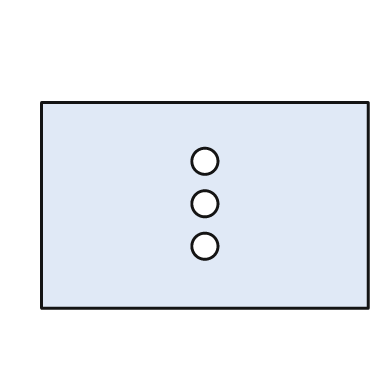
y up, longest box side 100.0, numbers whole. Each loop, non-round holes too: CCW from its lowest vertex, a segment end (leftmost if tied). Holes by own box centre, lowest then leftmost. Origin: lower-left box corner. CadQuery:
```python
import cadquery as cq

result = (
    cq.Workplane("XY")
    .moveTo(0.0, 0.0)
    .lineTo(100.0, 0.0)
    .lineTo(100.0, 63.0)
    .lineTo(0.0, 63.0)
    .close()
    .moveTo(50.0, 19.0)
    .circle(4.0)
    .moveTo(50.0, 32.0)
    .circle(4.0)
    .moveTo(50.0, 45.0)
    .circle(4.0)
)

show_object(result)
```